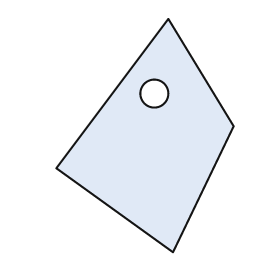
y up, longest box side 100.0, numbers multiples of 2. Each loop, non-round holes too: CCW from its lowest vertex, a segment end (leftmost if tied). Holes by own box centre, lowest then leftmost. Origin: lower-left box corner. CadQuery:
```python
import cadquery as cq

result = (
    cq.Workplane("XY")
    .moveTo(50.0, 0.0)
    .lineTo(76.0, 54.0)
    .lineTo(48.0, 100.0)
    .lineTo(0.0, 36.0)
    .close()
    .moveTo(42.0, 68.0)
    .circle(6.0)
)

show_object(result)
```